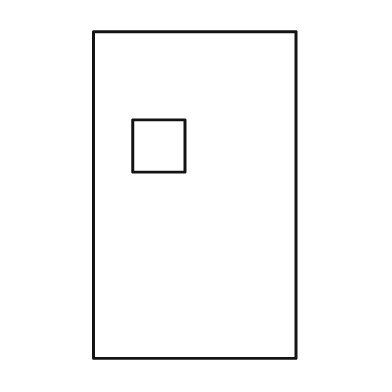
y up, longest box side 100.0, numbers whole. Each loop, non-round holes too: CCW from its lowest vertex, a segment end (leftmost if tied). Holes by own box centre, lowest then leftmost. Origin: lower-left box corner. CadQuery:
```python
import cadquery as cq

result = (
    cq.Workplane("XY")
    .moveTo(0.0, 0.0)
    .lineTo(62.0, 0.0)
    .lineTo(62.0, 100.0)
    .lineTo(0.0, 100.0)
    .close()
    .moveTo(12.0, 57.0)
    .lineTo(28.0, 57.0)
    .lineTo(28.0, 73.0)
    .lineTo(12.0, 73.0)
    .close()
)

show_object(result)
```